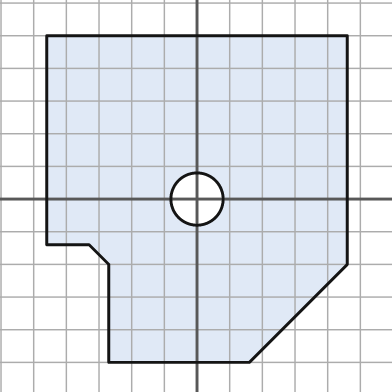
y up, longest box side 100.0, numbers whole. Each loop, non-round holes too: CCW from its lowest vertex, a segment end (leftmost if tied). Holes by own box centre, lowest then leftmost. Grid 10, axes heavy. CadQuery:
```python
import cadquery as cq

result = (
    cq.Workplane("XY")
    .moveTo(-27.0, -50.0)
    .lineTo(16.0, -50.0)
    .lineTo(46.0, -20.0)
    .lineTo(46.0, 50.0)
    .lineTo(-46.0, 50.0)
    .lineTo(-46.0, -14.0)
    .lineTo(-33.0, -14.0)
    .lineTo(-27.0, -20.0)
    .close()
    .moveTo(0.0, 0.0)
    .circle(8.0)
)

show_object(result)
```